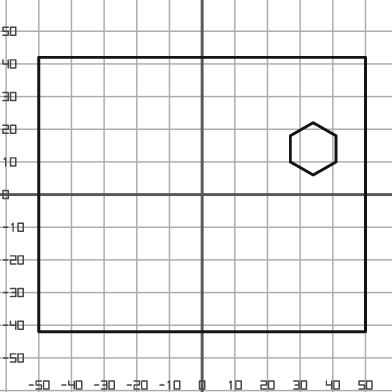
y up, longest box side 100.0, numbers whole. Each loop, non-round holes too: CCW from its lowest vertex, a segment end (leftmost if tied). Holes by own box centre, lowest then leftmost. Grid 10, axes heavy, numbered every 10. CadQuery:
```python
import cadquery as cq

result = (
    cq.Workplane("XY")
    .moveTo(-50.0, -42.0)
    .lineTo(50.0, -42.0)
    .lineTo(50.0, 42.0)
    .lineTo(-50.0, 42.0)
    .close()
    .moveTo(34.0, 6.0)
    .lineTo(41.0, 10.0)
    .lineTo(41.0, 18.0)
    .lineTo(34.0, 22.0)
    .lineTo(27.0, 18.0)
    .lineTo(27.0, 10.0)
    .close()
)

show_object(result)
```